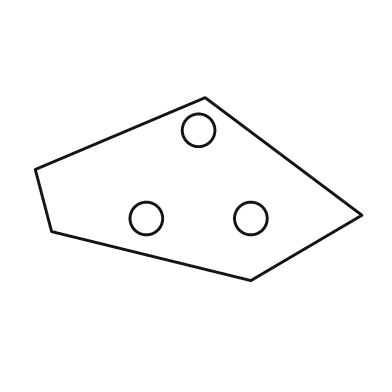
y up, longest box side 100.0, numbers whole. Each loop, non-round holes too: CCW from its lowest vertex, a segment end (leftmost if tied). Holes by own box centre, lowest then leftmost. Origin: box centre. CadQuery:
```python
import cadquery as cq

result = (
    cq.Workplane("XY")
    .moveTo(16.0, -28.0)
    .lineTo(50.0, -8.0)
    .lineTo(2.0, 28.0)
    .lineTo(-50.0, 6.0)
    .lineTo(-45.0, -13.0)
    .close()
    .moveTo(-16.0, -9.0)
    .circle(5.0)
    .moveTo(16.0, -9.0)
    .circle(5.0)
    .moveTo(0.0, 18.0)
    .circle(5.0)
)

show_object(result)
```